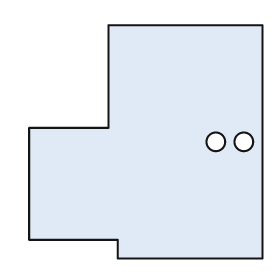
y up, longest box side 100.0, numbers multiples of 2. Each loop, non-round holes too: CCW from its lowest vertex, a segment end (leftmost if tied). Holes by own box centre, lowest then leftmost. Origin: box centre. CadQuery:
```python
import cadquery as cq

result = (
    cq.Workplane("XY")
    .moveTo(-12.0, -50.0)
    .lineTo(50.0, -50.0)
    .lineTo(50.0, 50.0)
    .lineTo(-16.0, 50.0)
    .lineTo(-16.0, 6.0)
    .lineTo(-50.0, 6.0)
    .lineTo(-50.0, -42.0)
    .lineTo(-12.0, -42.0)
    .close()
    .moveTo(30.0, 0.0)
    .circle(4.0)
    .moveTo(42.0, 0.0)
    .circle(4.0)
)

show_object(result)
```